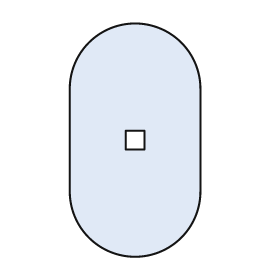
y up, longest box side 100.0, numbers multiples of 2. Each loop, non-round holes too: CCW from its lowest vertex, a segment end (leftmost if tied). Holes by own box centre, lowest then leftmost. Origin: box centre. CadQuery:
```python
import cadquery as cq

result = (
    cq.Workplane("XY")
    .moveTo(-28.0, -22.0)
    .threePointArc((0.0, -50.0), (28.0, -22.0))
    .lineTo(28.0, 22.0)
    .threePointArc((0.0, 50.0), (-28.0, 22.0))
    .close()
    .moveTo(-4.0, -4.0)
    .lineTo(4.0, -4.0)
    .lineTo(4.0, 4.0)
    .lineTo(-4.0, 4.0)
    .close()
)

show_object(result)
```